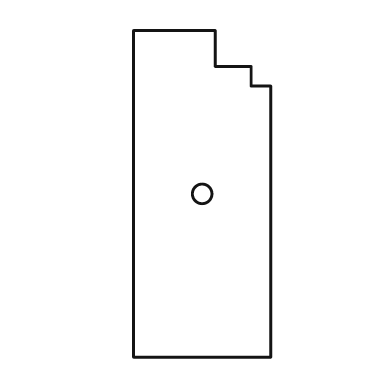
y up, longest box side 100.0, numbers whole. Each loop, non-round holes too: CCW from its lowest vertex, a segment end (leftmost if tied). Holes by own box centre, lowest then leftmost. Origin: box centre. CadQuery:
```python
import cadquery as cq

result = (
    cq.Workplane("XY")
    .moveTo(-21.0, -50.0)
    .lineTo(21.0, -50.0)
    .lineTo(21.0, 33.0)
    .lineTo(15.0, 33.0)
    .lineTo(15.0, 39.0)
    .lineTo(4.0, 39.0)
    .lineTo(4.0, 50.0)
    .lineTo(-21.0, 50.0)
    .close()
    .moveTo(0.0, 0.0)
    .circle(3.0)
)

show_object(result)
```